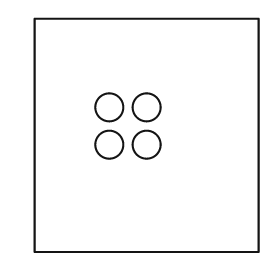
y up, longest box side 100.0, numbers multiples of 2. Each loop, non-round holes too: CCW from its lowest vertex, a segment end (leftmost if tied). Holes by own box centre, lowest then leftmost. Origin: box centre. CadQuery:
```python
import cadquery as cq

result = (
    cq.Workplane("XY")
    .moveTo(-48.0, -50.0)
    .lineTo(48.0, -50.0)
    .lineTo(48.0, 50.0)
    .lineTo(-48.0, 50.0)
    .close()
    .moveTo(-16.0, -4.0)
    .circle(6.0)
    .moveTo(0.0, -4.0)
    .circle(6.0)
    .moveTo(-16.0, 12.0)
    .circle(6.0)
    .moveTo(0.0, 12.0)
    .circle(6.0)
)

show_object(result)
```